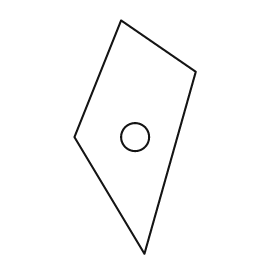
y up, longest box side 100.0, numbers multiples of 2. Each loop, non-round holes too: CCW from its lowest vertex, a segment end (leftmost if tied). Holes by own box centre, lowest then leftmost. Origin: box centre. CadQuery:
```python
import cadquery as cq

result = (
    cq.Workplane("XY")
    .moveTo(4.0, -50.0)
    .lineTo(26.0, 28.0)
    .lineTo(-6.0, 50.0)
    .lineTo(-26.0, 0.0)
    .close()
    .moveTo(0.0, 0.0)
    .circle(6.0)
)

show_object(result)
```